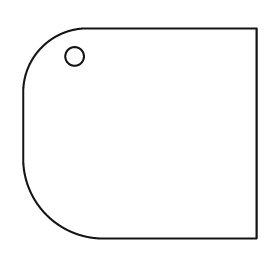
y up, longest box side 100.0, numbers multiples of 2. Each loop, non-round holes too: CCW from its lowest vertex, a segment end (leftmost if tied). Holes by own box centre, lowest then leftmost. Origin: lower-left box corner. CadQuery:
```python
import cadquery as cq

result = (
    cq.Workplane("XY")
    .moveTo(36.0, 0.0)
    .lineTo(100.0, 0.0)
    .lineTo(100.0, 90.0)
    .lineTo(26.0, 90.0)
    .threePointArc((8.0, 82.0), (0.0, 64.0))
    .lineTo(0.0, 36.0)
    .threePointArc((10.0, 10.0), (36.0, 0.0))
    .close()
    .moveTo(22.0, 78.0)
    .circle(4.0)
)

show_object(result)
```